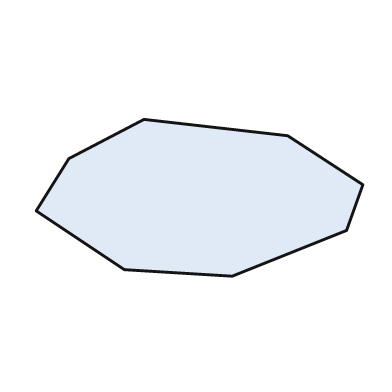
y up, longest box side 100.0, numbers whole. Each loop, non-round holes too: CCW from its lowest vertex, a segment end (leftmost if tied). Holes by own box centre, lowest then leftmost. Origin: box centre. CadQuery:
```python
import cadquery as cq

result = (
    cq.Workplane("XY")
    .moveTo(10.0, -24.0)
    .lineTo(45.0, -10.0)
    .lineTo(50.0, 4.0)
    .lineTo(27.0, 19.0)
    .lineTo(-17.0, 24.0)
    .lineTo(-40.0, 12.0)
    .lineTo(-50.0, -4.0)
    .lineTo(-23.0, -22.0)
    .close()
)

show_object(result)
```